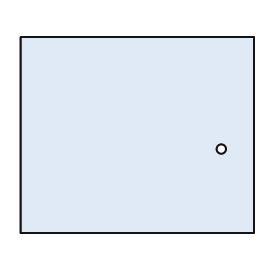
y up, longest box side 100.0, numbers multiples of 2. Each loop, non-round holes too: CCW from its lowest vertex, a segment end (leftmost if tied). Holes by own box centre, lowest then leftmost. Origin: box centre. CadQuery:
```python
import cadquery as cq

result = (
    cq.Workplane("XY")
    .moveTo(-50.0, -42.0)
    .lineTo(50.0, -42.0)
    .lineTo(50.0, 42.0)
    .lineTo(-50.0, 42.0)
    .close()
    .moveTo(36.0, -6.0)
    .circle(2.0)
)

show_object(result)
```